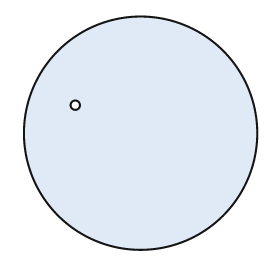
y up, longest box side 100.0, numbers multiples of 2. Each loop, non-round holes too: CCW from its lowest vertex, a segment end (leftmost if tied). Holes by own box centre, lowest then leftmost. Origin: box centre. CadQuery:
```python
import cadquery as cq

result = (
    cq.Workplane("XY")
    .moveTo(0.0, 0.0)
    .circle(50.0)
    .moveTo(-28.0, 12.0)
    .circle(2.0)
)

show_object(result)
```